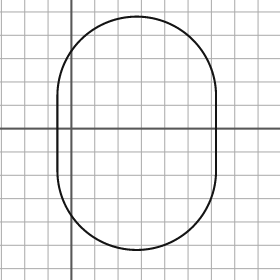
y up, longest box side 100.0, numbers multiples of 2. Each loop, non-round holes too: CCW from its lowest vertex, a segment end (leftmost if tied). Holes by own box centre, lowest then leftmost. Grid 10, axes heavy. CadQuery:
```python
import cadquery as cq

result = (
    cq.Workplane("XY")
    .moveTo(-6.0, -18.0)
    .threePointArc((28.0, -52.0), (62.0, -18.0))
    .lineTo(62.0, 14.0)
    .threePointArc((28.0, 48.0), (-6.0, 14.0))
    .close()
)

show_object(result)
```